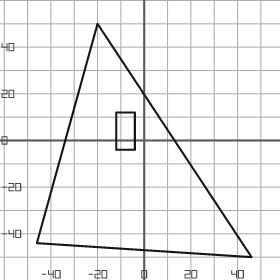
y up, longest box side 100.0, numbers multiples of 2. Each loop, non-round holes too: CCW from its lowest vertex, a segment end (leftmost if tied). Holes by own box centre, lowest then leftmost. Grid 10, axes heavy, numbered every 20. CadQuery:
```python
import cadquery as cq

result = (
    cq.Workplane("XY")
    .moveTo(46.0, -50.0)
    .lineTo(-20.0, 50.0)
    .lineTo(-46.0, -44.0)
    .close()
    .moveTo(-12.0, -4.0)
    .lineTo(-4.0, -4.0)
    .lineTo(-4.0, 12.0)
    .lineTo(-12.0, 12.0)
    .close()
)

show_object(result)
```